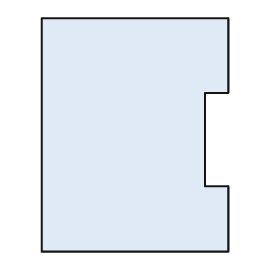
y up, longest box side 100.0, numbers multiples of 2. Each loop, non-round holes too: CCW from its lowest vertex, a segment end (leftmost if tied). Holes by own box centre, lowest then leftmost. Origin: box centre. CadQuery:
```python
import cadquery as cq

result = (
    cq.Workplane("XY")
    .moveTo(-40.0, -50.0)
    .lineTo(40.0, -50.0)
    .lineTo(40.0, -22.0)
    .lineTo(30.0, -22.0)
    .lineTo(30.0, 18.0)
    .lineTo(40.0, 18.0)
    .lineTo(40.0, 50.0)
    .lineTo(-40.0, 50.0)
    .close()
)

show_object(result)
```